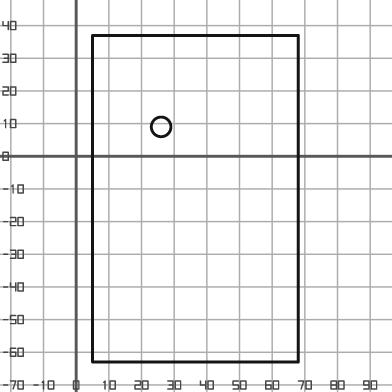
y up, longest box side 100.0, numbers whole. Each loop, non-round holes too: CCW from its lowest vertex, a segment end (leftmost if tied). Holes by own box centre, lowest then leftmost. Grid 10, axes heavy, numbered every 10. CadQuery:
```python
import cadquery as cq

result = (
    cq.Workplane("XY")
    .moveTo(5.0, -63.0)
    .lineTo(68.0, -63.0)
    .lineTo(68.0, 37.0)
    .lineTo(5.0, 37.0)
    .close()
    .moveTo(26.0, 9.0)
    .circle(3.0)
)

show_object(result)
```